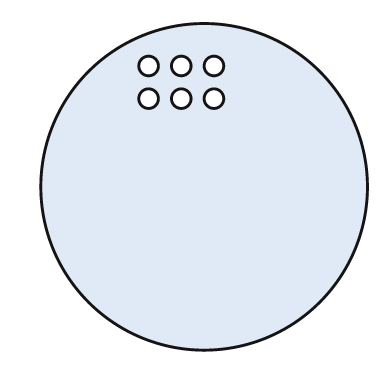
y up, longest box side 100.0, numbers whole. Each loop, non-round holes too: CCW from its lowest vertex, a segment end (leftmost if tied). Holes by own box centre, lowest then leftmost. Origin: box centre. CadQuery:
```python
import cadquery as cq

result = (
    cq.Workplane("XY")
    .moveTo(0.0, 0.0)
    .circle(50.0)
    .moveTo(-17.0, 27.0)
    .circle(3.0)
    .moveTo(-7.0, 27.0)
    .circle(3.0)
    .moveTo(3.0, 27.0)
    .circle(3.0)
    .moveTo(-17.0, 37.0)
    .circle(3.0)
    .moveTo(-7.0, 37.0)
    .circle(3.0)
    .moveTo(3.0, 37.0)
    .circle(3.0)
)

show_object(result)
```